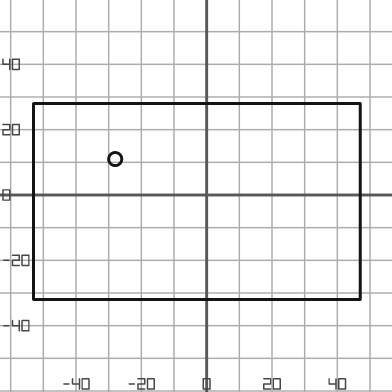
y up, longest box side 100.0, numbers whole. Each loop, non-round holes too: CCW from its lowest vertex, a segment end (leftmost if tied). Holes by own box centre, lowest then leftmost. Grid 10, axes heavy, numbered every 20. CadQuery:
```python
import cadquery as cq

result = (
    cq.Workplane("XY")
    .moveTo(-53.0, -32.0)
    .lineTo(47.0, -32.0)
    .lineTo(47.0, 28.0)
    .lineTo(-53.0, 28.0)
    .close()
    .moveTo(-28.0, 11.0)
    .circle(2.0)
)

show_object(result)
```